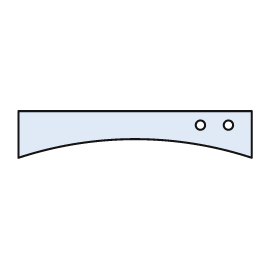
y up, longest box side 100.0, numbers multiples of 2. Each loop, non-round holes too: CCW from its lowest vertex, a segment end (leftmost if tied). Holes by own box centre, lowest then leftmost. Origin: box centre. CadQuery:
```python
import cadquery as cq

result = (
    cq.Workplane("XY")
    .moveTo(-50.0, -10.0)
    .threePointArc((0.0, -2.0), (50.0, -10.0))
    .lineTo(50.0, 10.0)
    .lineTo(-50.0, 10.0)
    .close()
    .moveTo(28.0, 4.0)
    .circle(2.0)
    .moveTo(40.0, 4.0)
    .circle(2.0)
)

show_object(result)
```